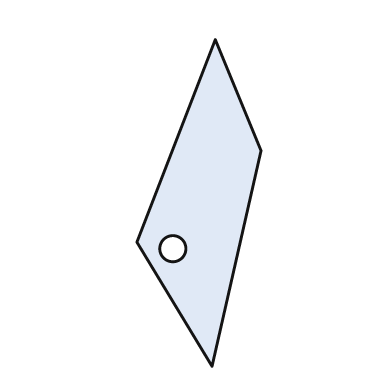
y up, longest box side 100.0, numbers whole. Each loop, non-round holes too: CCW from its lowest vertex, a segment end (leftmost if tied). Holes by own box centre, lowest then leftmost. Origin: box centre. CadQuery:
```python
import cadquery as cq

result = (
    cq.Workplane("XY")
    .moveTo(4.0, -50.0)
    .lineTo(19.0, 16.0)
    .lineTo(5.0, 50.0)
    .lineTo(-19.0, -12.0)
    .close()
    .moveTo(-8.0, -14.0)
    .circle(4.0)
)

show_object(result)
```